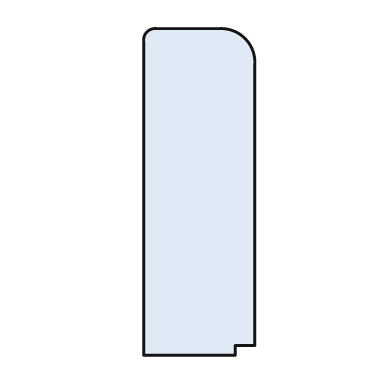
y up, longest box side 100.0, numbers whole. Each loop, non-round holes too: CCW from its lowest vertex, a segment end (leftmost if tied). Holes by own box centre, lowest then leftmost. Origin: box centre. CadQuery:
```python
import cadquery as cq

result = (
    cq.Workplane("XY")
    .moveTo(-17.0, -50.0)
    .lineTo(11.0, -50.0)
    .lineTo(11.0, -47.0)
    .lineTo(17.0, -47.0)
    .lineTo(17.0, 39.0)
    .threePointArc((14.0, 47.0), (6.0, 50.0))
    .lineTo(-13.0, 50.0)
    .threePointArc((-16.0, 49.0), (-17.0, 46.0))
    .close()
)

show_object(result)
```